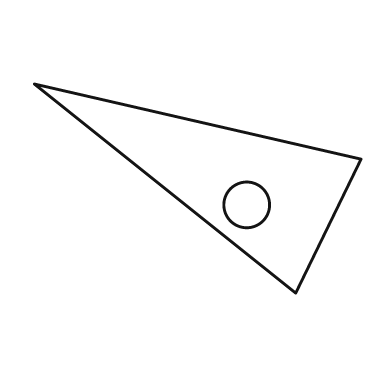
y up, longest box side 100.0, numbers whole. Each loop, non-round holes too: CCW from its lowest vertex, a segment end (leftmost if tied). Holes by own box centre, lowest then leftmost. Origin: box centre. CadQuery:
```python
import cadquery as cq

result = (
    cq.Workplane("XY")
    .moveTo(30.0, -32.0)
    .lineTo(50.0, 9.0)
    .lineTo(-50.0, 32.0)
    .close()
    .moveTo(15.0, -5.0)
    .circle(7.0)
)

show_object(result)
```